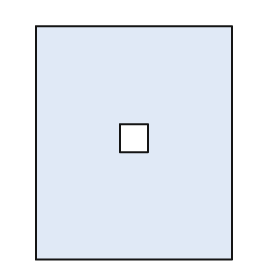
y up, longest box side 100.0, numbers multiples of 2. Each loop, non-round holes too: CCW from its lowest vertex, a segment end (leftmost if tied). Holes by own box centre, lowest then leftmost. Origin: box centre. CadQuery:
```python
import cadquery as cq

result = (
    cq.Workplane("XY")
    .moveTo(-42.0, -50.0)
    .lineTo(42.0, -50.0)
    .lineTo(42.0, 50.0)
    .lineTo(-42.0, 50.0)
    .close()
    .moveTo(-6.0, -4.0)
    .lineTo(6.0, -4.0)
    .lineTo(6.0, 8.0)
    .lineTo(-6.0, 8.0)
    .close()
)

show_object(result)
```